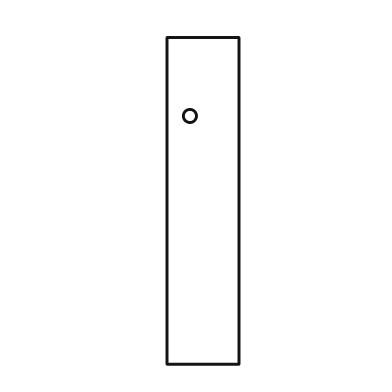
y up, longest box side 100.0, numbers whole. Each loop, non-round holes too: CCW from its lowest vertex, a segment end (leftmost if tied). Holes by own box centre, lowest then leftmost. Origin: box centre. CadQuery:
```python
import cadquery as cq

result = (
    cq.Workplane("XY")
    .moveTo(-11.0, -50.0)
    .lineTo(11.0, -50.0)
    .lineTo(11.0, 50.0)
    .lineTo(-11.0, 50.0)
    .close()
    .moveTo(-4.0, 26.0)
    .circle(2.0)
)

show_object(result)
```